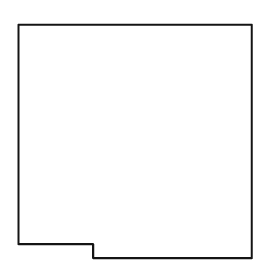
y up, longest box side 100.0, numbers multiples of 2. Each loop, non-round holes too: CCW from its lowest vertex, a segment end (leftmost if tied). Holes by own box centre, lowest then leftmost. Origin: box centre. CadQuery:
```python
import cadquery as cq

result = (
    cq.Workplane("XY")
    .moveTo(-18.0, -50.0)
    .lineTo(50.0, -50.0)
    .lineTo(50.0, 50.0)
    .lineTo(-50.0, 50.0)
    .lineTo(-50.0, -44.0)
    .lineTo(-18.0, -44.0)
    .close()
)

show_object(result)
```